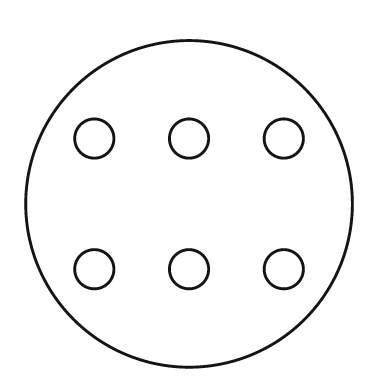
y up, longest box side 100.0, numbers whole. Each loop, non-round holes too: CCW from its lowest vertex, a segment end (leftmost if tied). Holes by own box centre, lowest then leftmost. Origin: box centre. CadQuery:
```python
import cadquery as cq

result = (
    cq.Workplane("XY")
    .moveTo(0.0, 0.0)
    .circle(50.0)
    .moveTo(-29.0, -20.0)
    .circle(6.0)
    .moveTo(0.0, -20.0)
    .circle(6.0)
    .moveTo(29.0, -20.0)
    .circle(6.0)
    .moveTo(-29.0, 20.0)
    .circle(6.0)
    .moveTo(0.0, 20.0)
    .circle(6.0)
    .moveTo(29.0, 20.0)
    .circle(6.0)
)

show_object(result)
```